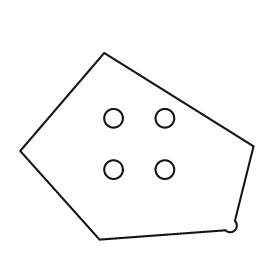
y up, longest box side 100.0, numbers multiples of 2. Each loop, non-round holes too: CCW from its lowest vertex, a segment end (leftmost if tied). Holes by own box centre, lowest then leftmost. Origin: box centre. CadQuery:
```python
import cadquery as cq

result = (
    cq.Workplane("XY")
    .moveTo(-16.0, -40.0)
    .lineTo(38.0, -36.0)
    .threePointArc((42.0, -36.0), (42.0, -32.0))
    .lineTo(50.0, 0.0)
    .lineTo(-14.0, 40.0)
    .lineTo(-50.0, -2.0)
    .close()
    .moveTo(-10.0, -10.0)
    .circle(4.0)
    .moveTo(12.0, -10.0)
    .circle(4.0)
    .moveTo(-10.0, 12.0)
    .circle(4.0)
    .moveTo(12.0, 12.0)
    .circle(4.0)
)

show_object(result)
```